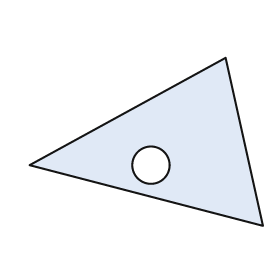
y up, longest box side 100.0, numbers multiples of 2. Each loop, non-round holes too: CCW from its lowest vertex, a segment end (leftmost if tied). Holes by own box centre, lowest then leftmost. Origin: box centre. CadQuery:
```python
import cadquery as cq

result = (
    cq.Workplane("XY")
    .moveTo(50.0, -36.0)
    .lineTo(34.0, 36.0)
    .lineTo(-50.0, -10.0)
    .close()
    .moveTo(2.0, -10.0)
    .circle(8.0)
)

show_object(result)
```